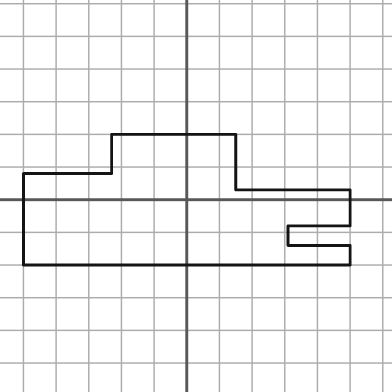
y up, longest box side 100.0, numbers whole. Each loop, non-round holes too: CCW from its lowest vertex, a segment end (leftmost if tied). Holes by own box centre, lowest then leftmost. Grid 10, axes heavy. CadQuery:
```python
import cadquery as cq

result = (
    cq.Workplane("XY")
    .moveTo(-50.0, -20.0)
    .lineTo(50.0, -20.0)
    .lineTo(50.0, -14.0)
    .lineTo(31.0, -14.0)
    .lineTo(31.0, -8.0)
    .lineTo(50.0, -8.0)
    .lineTo(50.0, 3.0)
    .lineTo(15.0, 3.0)
    .lineTo(15.0, 20.0)
    .lineTo(-23.0, 20.0)
    .lineTo(-23.0, 8.0)
    .lineTo(-50.0, 8.0)
    .close()
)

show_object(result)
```